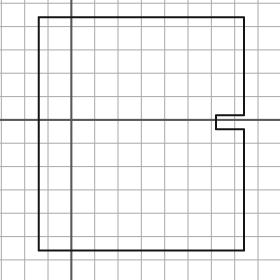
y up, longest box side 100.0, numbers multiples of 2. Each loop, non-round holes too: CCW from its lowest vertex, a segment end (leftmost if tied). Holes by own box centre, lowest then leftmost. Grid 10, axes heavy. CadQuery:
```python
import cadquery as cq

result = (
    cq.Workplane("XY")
    .moveTo(-14.0, -56.0)
    .lineTo(74.0, -56.0)
    .lineTo(74.0, -4.0)
    .lineTo(62.0, -4.0)
    .lineTo(62.0, 2.0)
    .lineTo(74.0, 2.0)
    .lineTo(74.0, 44.0)
    .lineTo(-14.0, 44.0)
    .close()
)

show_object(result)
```